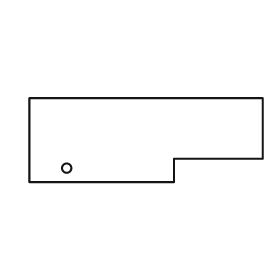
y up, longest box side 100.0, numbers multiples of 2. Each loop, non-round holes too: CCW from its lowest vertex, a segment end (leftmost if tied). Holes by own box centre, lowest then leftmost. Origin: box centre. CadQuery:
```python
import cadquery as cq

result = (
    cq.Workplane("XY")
    .moveTo(-50.0, -18.0)
    .lineTo(12.0, -18.0)
    .lineTo(12.0, -8.0)
    .lineTo(50.0, -8.0)
    .lineTo(50.0, 18.0)
    .lineTo(-50.0, 18.0)
    .close()
    .moveTo(-34.0, -12.0)
    .circle(2.0)
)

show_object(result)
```